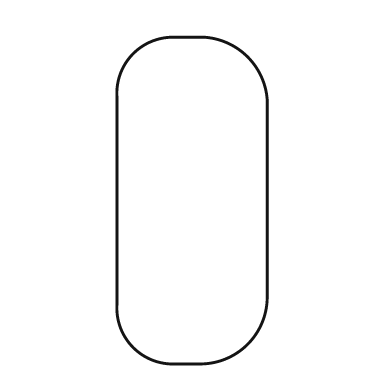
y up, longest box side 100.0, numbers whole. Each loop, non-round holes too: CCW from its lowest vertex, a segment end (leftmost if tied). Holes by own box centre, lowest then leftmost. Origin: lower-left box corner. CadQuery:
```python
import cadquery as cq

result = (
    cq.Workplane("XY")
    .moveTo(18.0, 0.0)
    .lineTo(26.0, 0.0)
    .threePointArc((40.0, 6.0), (46.0, 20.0))
    .lineTo(46.0, 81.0)
    .threePointArc((40.0, 94.0), (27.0, 100.0))
    .lineTo(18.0, 100.0)
    .threePointArc((5.0, 95.0), (0.0, 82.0))
    .lineTo(0.0, 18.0)
    .threePointArc((5.0, 5.0), (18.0, 0.0))
    .close()
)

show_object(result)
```